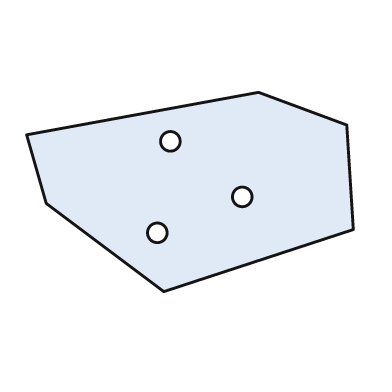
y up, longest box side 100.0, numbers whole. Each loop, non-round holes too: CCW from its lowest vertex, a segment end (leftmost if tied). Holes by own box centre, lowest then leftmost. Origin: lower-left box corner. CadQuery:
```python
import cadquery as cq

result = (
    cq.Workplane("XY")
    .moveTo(42.0, 0.0)
    .lineTo(100.0, 19.0)
    .lineTo(98.0, 51.0)
    .lineTo(71.0, 61.0)
    .lineTo(0.0, 48.0)
    .lineTo(6.0, 27.0)
    .close()
    .moveTo(40.0, 18.0)
    .circle(3.0)
    .moveTo(66.0, 29.0)
    .circle(3.0)
    .moveTo(44.0, 46.0)
    .circle(3.0)
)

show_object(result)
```